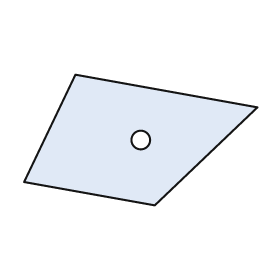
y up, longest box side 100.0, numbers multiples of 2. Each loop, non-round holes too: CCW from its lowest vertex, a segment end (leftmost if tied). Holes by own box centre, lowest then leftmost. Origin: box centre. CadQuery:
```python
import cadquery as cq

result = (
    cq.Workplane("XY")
    .moveTo(6.0, -28.0)
    .lineTo(50.0, 14.0)
    .lineTo(-28.0, 28.0)
    .lineTo(-50.0, -18.0)
    .close()
    .moveTo(0.0, 0.0)
    .circle(4.0)
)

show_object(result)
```